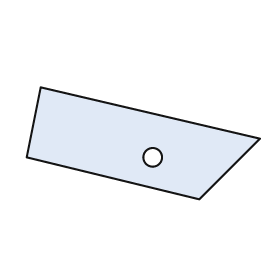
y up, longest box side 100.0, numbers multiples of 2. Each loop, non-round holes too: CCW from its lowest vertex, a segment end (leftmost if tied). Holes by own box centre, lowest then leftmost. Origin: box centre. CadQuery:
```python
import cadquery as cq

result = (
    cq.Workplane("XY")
    .moveTo(24.0, -24.0)
    .lineTo(50.0, 2.0)
    .lineTo(-44.0, 24.0)
    .lineTo(-50.0, -6.0)
    .close()
    .moveTo(4.0, -6.0)
    .circle(4.0)
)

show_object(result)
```